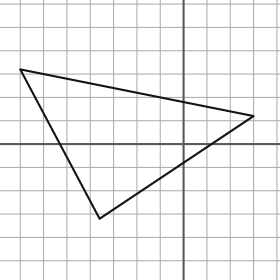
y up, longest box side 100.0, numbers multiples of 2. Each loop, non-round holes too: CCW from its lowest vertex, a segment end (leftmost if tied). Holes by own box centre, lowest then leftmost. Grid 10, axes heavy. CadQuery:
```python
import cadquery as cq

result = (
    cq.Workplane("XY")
    .moveTo(-36.0, -32.0)
    .lineTo(30.0, 12.0)
    .lineTo(-70.0, 32.0)
    .close()
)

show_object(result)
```